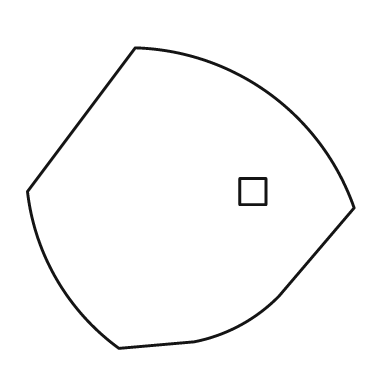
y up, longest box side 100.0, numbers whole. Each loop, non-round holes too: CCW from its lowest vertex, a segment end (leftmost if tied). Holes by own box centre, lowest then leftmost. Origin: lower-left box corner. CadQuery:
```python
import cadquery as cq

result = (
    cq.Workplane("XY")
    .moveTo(28.0, 0.0)
    .lineTo(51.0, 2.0)
    .threePointArc((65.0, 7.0), (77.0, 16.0))
    .lineTo(100.0, 43.0)
    .threePointArc((74.0, 78.0), (33.0, 92.0))
    .lineTo(0.0, 48.0)
    .threePointArc((9.0, 21.0), (28.0, 0.0))
    .close()
    .moveTo(65.0, 44.0)
    .lineTo(73.0, 44.0)
    .lineTo(73.0, 52.0)
    .lineTo(65.0, 52.0)
    .close()
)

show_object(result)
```